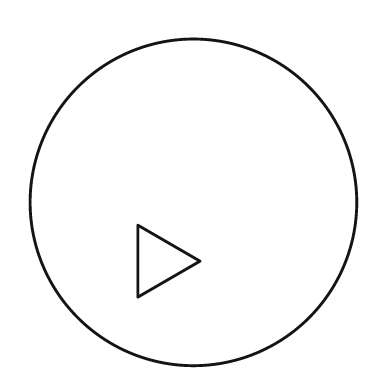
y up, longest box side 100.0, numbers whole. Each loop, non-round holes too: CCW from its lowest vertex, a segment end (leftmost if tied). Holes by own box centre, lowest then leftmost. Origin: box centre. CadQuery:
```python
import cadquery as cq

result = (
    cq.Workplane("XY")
    .moveTo(0.0, 0.0)
    .circle(50.0)
    .moveTo(-17.0, -29.0)
    .lineTo(2.0, -18.0)
    .lineTo(-17.0, -7.0)
    .close()
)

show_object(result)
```